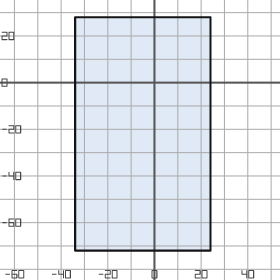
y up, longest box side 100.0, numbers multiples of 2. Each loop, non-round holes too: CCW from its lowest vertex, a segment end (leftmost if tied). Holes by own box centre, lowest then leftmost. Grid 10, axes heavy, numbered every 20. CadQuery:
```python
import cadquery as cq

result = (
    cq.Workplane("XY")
    .moveTo(-34.0, -72.0)
    .lineTo(24.0, -72.0)
    .lineTo(24.0, 28.0)
    .lineTo(-34.0, 28.0)
    .close()
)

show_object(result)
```